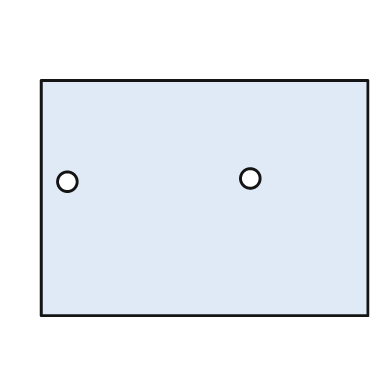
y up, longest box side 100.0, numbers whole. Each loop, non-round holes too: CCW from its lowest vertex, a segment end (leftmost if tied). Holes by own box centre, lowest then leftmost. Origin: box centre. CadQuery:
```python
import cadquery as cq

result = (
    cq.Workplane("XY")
    .moveTo(-50.0, -36.0)
    .lineTo(50.0, -36.0)
    .lineTo(50.0, 36.0)
    .lineTo(-50.0, 36.0)
    .close()
    .moveTo(-42.0, 5.0)
    .circle(3.0)
    .moveTo(14.0, 6.0)
    .circle(3.0)
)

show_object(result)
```